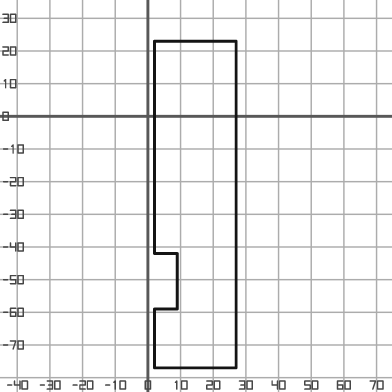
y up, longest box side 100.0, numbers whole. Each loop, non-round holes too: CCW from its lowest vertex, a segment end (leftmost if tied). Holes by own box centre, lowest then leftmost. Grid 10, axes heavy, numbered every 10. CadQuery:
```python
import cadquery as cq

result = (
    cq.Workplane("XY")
    .moveTo(2.0, -77.0)
    .lineTo(27.0, -77.0)
    .lineTo(27.0, 23.0)
    .lineTo(2.0, 23.0)
    .lineTo(2.0, -42.0)
    .lineTo(9.0, -42.0)
    .lineTo(9.0, -59.0)
    .lineTo(2.0, -59.0)
    .close()
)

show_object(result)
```